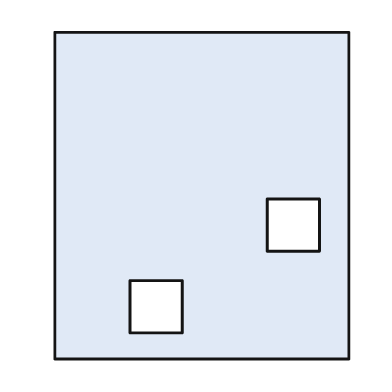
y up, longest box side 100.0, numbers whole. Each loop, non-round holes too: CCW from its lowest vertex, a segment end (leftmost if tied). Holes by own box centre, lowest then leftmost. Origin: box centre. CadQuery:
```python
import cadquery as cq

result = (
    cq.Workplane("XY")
    .moveTo(-45.0, -50.0)
    .lineTo(45.0, -50.0)
    .lineTo(45.0, 50.0)
    .lineTo(-45.0, 50.0)
    .close()
    .moveTo(-22.0, -42.0)
    .lineTo(-6.0, -42.0)
    .lineTo(-6.0, -26.0)
    .lineTo(-22.0, -26.0)
    .close()
    .moveTo(20.0, -17.0)
    .lineTo(36.0, -17.0)
    .lineTo(36.0, -1.0)
    .lineTo(20.0, -1.0)
    .close()
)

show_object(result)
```